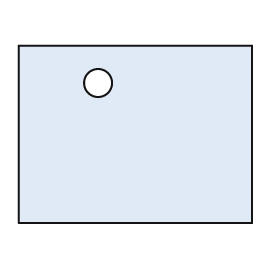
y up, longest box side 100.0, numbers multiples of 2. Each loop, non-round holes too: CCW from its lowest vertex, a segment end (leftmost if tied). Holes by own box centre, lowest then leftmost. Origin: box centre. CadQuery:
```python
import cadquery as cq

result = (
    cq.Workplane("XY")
    .moveTo(-50.0, -38.0)
    .lineTo(50.0, -38.0)
    .lineTo(50.0, 38.0)
    .lineTo(-50.0, 38.0)
    .close()
    .moveTo(-16.0, 22.0)
    .circle(6.0)
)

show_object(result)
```